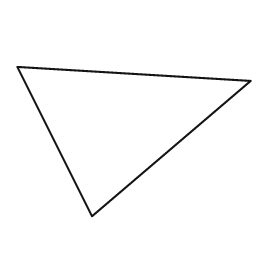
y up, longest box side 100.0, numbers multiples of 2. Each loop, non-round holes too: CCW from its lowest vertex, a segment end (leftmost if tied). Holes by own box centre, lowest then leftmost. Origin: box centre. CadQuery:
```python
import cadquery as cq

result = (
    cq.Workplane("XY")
    .moveTo(-18.0, -32.0)
    .lineTo(50.0, 26.0)
    .lineTo(-50.0, 32.0)
    .close()
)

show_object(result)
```